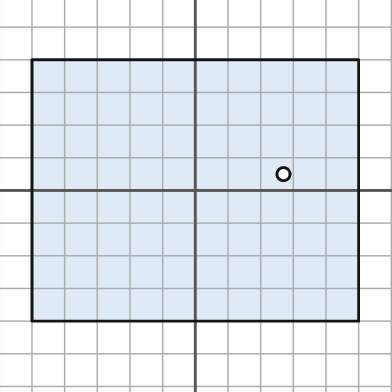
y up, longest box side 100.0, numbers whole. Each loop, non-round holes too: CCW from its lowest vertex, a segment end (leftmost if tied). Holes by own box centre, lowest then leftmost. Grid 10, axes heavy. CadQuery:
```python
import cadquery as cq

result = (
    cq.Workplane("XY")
    .moveTo(-50.0, -40.0)
    .lineTo(50.0, -40.0)
    .lineTo(50.0, 40.0)
    .lineTo(-50.0, 40.0)
    .close()
    .moveTo(27.0, 5.0)
    .circle(2.0)
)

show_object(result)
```